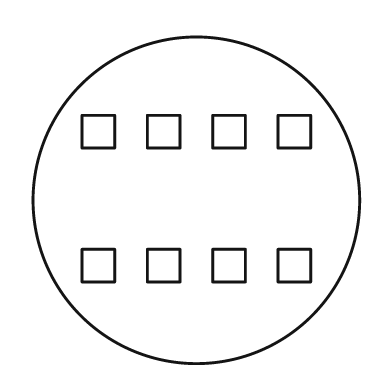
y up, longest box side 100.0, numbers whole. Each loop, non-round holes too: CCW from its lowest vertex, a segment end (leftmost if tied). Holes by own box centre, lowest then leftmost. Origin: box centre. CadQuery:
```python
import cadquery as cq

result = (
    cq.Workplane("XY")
    .moveTo(0.0, 0.0)
    .circle(50.0)
    .moveTo(-35.0, -25.0)
    .lineTo(-25.0, -25.0)
    .lineTo(-25.0, -15.0)
    .lineTo(-35.0, -15.0)
    .close()
    .moveTo(-15.0, -25.0)
    .lineTo(-5.0, -25.0)
    .lineTo(-5.0, -15.0)
    .lineTo(-15.0, -15.0)
    .close()
    .moveTo(5.0, -25.0)
    .lineTo(15.0, -25.0)
    .lineTo(15.0, -15.0)
    .lineTo(5.0, -15.0)
    .close()
    .moveTo(25.0, -25.0)
    .lineTo(35.0, -25.0)
    .lineTo(35.0, -15.0)
    .lineTo(25.0, -15.0)
    .close()
    .moveTo(-35.0, 16.0)
    .lineTo(-25.0, 16.0)
    .lineTo(-25.0, 26.0)
    .lineTo(-35.0, 26.0)
    .close()
    .moveTo(-15.0, 16.0)
    .lineTo(-5.0, 16.0)
    .lineTo(-5.0, 26.0)
    .lineTo(-15.0, 26.0)
    .close()
    .moveTo(5.0, 16.0)
    .lineTo(15.0, 16.0)
    .lineTo(15.0, 26.0)
    .lineTo(5.0, 26.0)
    .close()
    .moveTo(25.0, 16.0)
    .lineTo(35.0, 16.0)
    .lineTo(35.0, 26.0)
    .lineTo(25.0, 26.0)
    .close()
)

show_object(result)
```